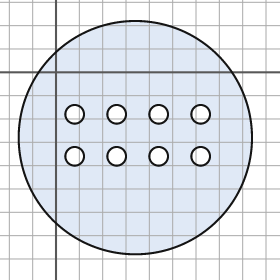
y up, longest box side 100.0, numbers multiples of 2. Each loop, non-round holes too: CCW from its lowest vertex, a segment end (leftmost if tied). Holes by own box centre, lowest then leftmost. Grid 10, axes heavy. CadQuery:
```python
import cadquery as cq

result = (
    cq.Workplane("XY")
    .moveTo(34.0, -28.0)
    .circle(50.0)
    .moveTo(8.0, -36.0)
    .circle(4.0)
    .moveTo(26.0, -36.0)
    .circle(4.0)
    .moveTo(44.0, -36.0)
    .circle(4.0)
    .moveTo(62.0, -36.0)
    .circle(4.0)
    .moveTo(8.0, -18.0)
    .circle(4.0)
    .moveTo(26.0, -18.0)
    .circle(4.0)
    .moveTo(44.0, -18.0)
    .circle(4.0)
    .moveTo(62.0, -18.0)
    .circle(4.0)
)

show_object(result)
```